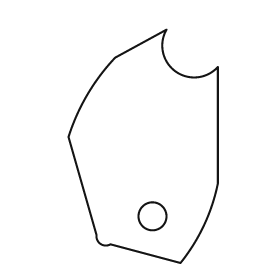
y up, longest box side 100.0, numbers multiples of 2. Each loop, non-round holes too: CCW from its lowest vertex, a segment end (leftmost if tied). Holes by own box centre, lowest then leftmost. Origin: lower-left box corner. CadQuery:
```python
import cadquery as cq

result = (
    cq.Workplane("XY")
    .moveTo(48.0, 0.0)
    .threePointArc((58.0, 16.0), (64.0, 34.0))
    .lineTo(64.0, 84.0)
    .threePointArc((46.0, 82.0), (42.0, 100.0))
    .lineTo(20.0, 88.0)
    .threePointArc((8.0, 72.0), (0.0, 54.0))
    .lineTo(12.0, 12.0)
    .threePointArc((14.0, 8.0), (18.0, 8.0))
    .close()
    .moveTo(36.0, 20.0)
    .circle(6.0)
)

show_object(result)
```